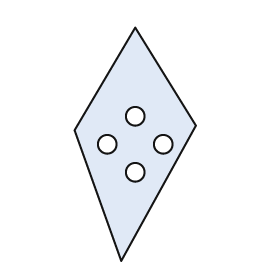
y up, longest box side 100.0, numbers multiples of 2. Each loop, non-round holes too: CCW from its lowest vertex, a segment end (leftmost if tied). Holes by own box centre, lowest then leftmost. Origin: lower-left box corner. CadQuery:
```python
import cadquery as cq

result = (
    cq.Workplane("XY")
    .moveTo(20.0, 0.0)
    .lineTo(52.0, 58.0)
    .lineTo(26.0, 100.0)
    .lineTo(0.0, 56.0)
    .close()
    .moveTo(26.0, 38.0)
    .circle(4.0)
    .moveTo(14.0, 50.0)
    .circle(4.0)
    .moveTo(38.0, 50.0)
    .circle(4.0)
    .moveTo(26.0, 62.0)
    .circle(4.0)
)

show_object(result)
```